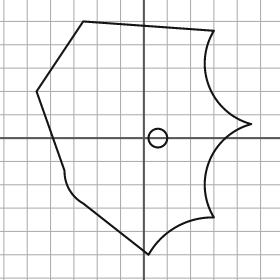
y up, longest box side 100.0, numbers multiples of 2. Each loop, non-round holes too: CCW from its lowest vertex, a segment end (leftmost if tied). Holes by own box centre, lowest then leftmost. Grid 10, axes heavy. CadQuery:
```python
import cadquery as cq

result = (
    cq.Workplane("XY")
    .moveTo(2.0, -50.0)
    .threePointArc((14.0, -38.0), (30.0, -34.0))
    .threePointArc((28.0, -10.0), (46.0, 6.0))
    .threePointArc((28.0, 22.0), (30.0, 46.0))
    .lineTo(-26.0, 50.0)
    .lineTo(-46.0, 20.0)
    .lineTo(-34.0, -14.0)
    .threePointArc((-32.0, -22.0), (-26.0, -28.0))
    .close()
    .moveTo(6.0, 0.0)
    .circle(4.0)
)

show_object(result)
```